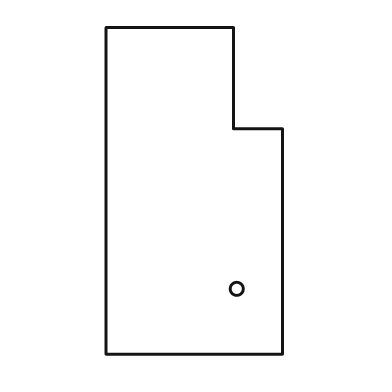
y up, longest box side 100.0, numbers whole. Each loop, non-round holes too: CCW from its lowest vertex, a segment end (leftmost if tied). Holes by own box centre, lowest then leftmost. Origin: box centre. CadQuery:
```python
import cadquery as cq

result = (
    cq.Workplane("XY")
    .moveTo(-27.0, -50.0)
    .lineTo(27.0, -50.0)
    .lineTo(27.0, 19.0)
    .lineTo(12.0, 19.0)
    .lineTo(12.0, 50.0)
    .lineTo(-27.0, 50.0)
    .close()
    .moveTo(13.0, -30.0)
    .circle(2.0)
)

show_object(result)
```